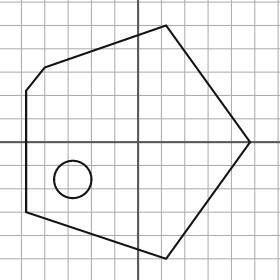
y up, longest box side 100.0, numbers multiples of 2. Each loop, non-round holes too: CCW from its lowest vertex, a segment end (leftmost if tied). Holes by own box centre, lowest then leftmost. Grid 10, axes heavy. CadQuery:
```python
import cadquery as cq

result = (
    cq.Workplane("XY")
    .moveTo(12.0, -50.0)
    .lineTo(48.0, 0.0)
    .lineTo(12.0, 50.0)
    .lineTo(-40.0, 32.0)
    .lineTo(-48.0, 22.0)
    .lineTo(-48.0, -30.0)
    .close()
    .moveTo(-28.0, -16.0)
    .circle(8.0)
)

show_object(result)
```